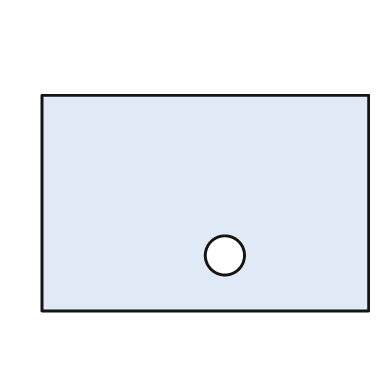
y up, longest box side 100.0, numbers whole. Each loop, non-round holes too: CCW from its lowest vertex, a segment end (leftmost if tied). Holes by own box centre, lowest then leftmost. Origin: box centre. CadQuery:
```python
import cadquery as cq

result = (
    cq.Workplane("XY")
    .moveTo(-50.0, -33.0)
    .lineTo(50.0, -33.0)
    .lineTo(50.0, 33.0)
    .lineTo(-50.0, 33.0)
    .close()
    .moveTo(6.0, -16.0)
    .circle(6.0)
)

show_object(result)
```